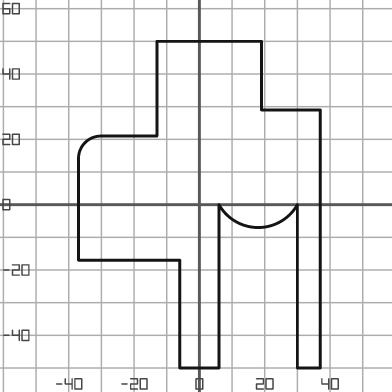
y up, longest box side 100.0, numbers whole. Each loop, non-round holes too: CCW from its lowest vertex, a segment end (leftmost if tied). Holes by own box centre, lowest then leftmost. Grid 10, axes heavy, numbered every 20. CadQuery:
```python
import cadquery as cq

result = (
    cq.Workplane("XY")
    .moveTo(-6.0, -50.0)
    .lineTo(6.0, -50.0)
    .lineTo(6.0, 0.0)
    .threePointArc((18.0, -7.0), (30.0, 0.0))
    .lineTo(30.0, -50.0)
    .lineTo(37.0, -50.0)
    .lineTo(37.0, 29.0)
    .lineTo(19.0, 29.0)
    .lineTo(19.0, 50.0)
    .lineTo(-13.0, 50.0)
    .lineTo(-13.0, 21.0)
    .lineTo(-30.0, 21.0)
    .threePointArc((-35.0, 19.0), (-37.0, 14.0))
    .lineTo(-37.0, -17.0)
    .lineTo(-6.0, -17.0)
    .close()
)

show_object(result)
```